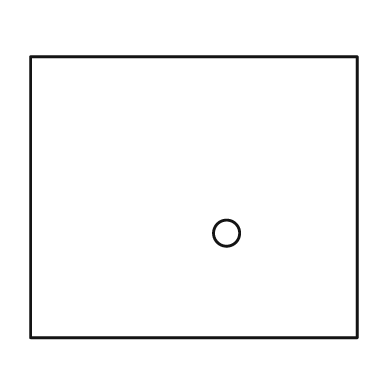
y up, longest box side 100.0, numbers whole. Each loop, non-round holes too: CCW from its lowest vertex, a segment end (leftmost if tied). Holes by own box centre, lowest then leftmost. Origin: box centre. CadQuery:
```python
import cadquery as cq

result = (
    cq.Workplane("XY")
    .moveTo(-50.0, -43.0)
    .lineTo(50.0, -43.0)
    .lineTo(50.0, 43.0)
    .lineTo(-50.0, 43.0)
    .close()
    .moveTo(10.0, -11.0)
    .circle(4.0)
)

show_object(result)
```